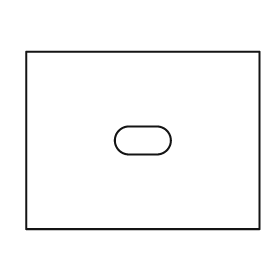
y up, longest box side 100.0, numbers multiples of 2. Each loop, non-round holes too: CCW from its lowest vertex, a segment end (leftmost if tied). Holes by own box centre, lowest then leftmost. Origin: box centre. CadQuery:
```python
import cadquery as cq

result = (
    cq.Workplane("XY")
    .moveTo(-50.0, -38.0)
    .lineTo(50.0, -38.0)
    .lineTo(50.0, 38.0)
    .lineTo(-50.0, 38.0)
    .close()
    .moveTo(-6.0, -6.0)
    .lineTo(6.0, -6.0)
    .threePointArc((12.0, 0.0), (6.0, 6.0))
    .lineTo(-6.0, 6.0)
    .threePointArc((-12.0, 0.0), (-6.0, -6.0))
    .close()
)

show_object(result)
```